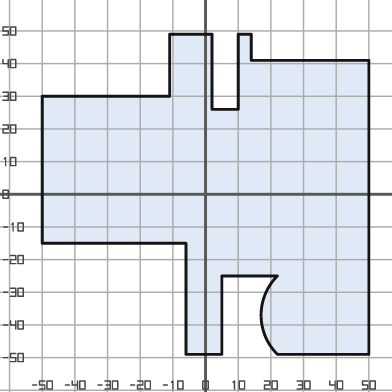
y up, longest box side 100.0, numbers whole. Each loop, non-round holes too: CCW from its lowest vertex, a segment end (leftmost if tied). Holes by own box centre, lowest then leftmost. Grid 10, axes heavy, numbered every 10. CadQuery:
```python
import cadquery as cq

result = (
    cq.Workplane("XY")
    .moveTo(-6.0, -49.0)
    .lineTo(5.0, -49.0)
    .lineTo(5.0, -25.0)
    .lineTo(22.0, -25.0)
    .threePointArc((17.0, -37.0), (22.0, -49.0))
    .lineTo(50.0, -49.0)
    .lineTo(50.0, 41.0)
    .lineTo(14.0, 41.0)
    .lineTo(14.0, 49.0)
    .lineTo(10.0, 49.0)
    .lineTo(10.0, 26.0)
    .lineTo(2.0, 26.0)
    .lineTo(2.0, 49.0)
    .lineTo(-11.0, 49.0)
    .lineTo(-11.0, 30.0)
    .lineTo(-50.0, 30.0)
    .lineTo(-50.0, -15.0)
    .lineTo(-6.0, -15.0)
    .close()
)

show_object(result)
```